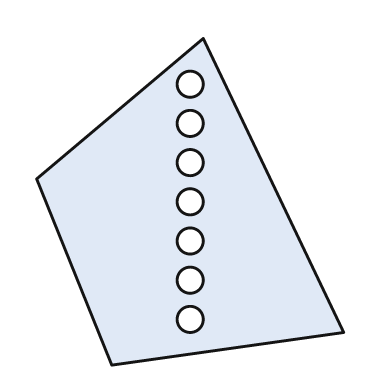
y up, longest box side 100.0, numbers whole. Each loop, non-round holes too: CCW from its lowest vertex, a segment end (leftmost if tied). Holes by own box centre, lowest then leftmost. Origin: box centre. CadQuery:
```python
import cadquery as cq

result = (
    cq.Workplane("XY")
    .moveTo(-24.0, -50.0)
    .lineTo(47.0, -40.0)
    .lineTo(4.0, 50.0)
    .lineTo(-47.0, 7.0)
    .close()
    .moveTo(0.0, -36.0)
    .circle(4.0)
    .moveTo(0.0, -24.0)
    .circle(4.0)
    .moveTo(0.0, -12.0)
    .circle(4.0)
    .moveTo(0.0, 0.0)
    .circle(4.0)
    .moveTo(0.0, 12.0)
    .circle(4.0)
    .moveTo(0.0, 24.0)
    .circle(4.0)
    .moveTo(0.0, 36.0)
    .circle(4.0)
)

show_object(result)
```